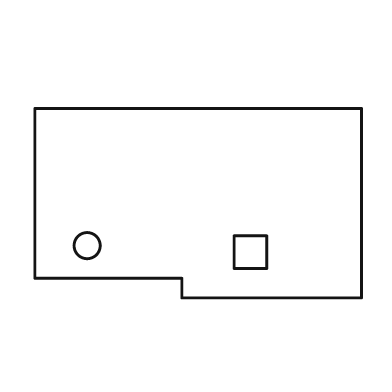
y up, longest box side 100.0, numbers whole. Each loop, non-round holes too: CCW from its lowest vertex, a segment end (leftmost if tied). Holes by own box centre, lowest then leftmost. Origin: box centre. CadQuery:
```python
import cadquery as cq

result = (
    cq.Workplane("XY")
    .moveTo(-5.0, -29.0)
    .lineTo(50.0, -29.0)
    .lineTo(50.0, 29.0)
    .lineTo(-50.0, 29.0)
    .lineTo(-50.0, -23.0)
    .lineTo(-5.0, -23.0)
    .close()
    .moveTo(11.0, -20.0)
    .lineTo(21.0, -20.0)
    .lineTo(21.0, -10.0)
    .lineTo(11.0, -10.0)
    .close()
    .moveTo(-34.0, -13.0)
    .circle(4.0)
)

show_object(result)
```